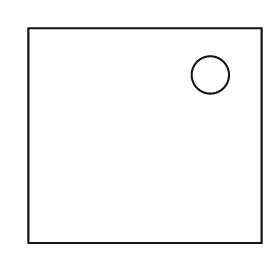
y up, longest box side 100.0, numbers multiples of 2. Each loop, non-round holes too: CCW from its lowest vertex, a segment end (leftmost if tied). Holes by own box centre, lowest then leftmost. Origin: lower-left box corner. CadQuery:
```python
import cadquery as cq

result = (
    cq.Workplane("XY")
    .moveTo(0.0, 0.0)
    .lineTo(100.0, 0.0)
    .lineTo(100.0, 92.0)
    .lineTo(0.0, 92.0)
    .close()
    .moveTo(78.0, 72.0)
    .circle(8.0)
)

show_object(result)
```